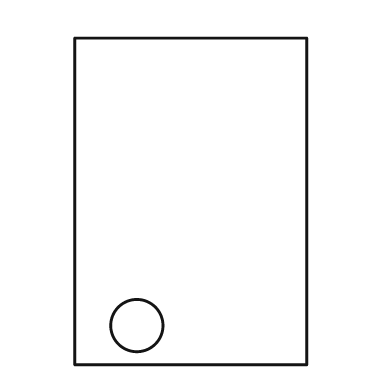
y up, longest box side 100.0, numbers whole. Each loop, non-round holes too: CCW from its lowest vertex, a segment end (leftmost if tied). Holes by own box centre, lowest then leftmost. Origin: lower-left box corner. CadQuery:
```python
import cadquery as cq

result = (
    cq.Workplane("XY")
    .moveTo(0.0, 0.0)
    .lineTo(71.0, 0.0)
    .lineTo(71.0, 100.0)
    .lineTo(0.0, 100.0)
    .close()
    .moveTo(19.0, 12.0)
    .circle(8.0)
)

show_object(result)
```